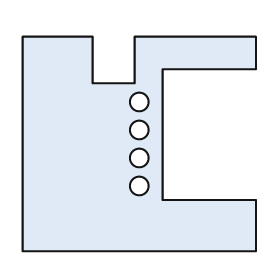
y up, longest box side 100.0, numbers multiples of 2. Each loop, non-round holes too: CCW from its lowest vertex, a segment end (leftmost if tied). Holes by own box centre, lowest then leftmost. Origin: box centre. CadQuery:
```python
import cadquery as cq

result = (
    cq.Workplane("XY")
    .moveTo(-50.0, -46.0)
    .lineTo(50.0, -46.0)
    .lineTo(50.0, -24.0)
    .lineTo(10.0, -24.0)
    .lineTo(10.0, 32.0)
    .lineTo(50.0, 32.0)
    .lineTo(50.0, 46.0)
    .lineTo(-2.0, 46.0)
    .lineTo(-2.0, 26.0)
    .lineTo(-20.0, 26.0)
    .lineTo(-20.0, 46.0)
    .lineTo(-50.0, 46.0)
    .close()
    .moveTo(0.0, -18.0)
    .circle(4.0)
    .moveTo(0.0, -6.0)
    .circle(4.0)
    .moveTo(0.0, 6.0)
    .circle(4.0)
    .moveTo(0.0, 18.0)
    .circle(4.0)
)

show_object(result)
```